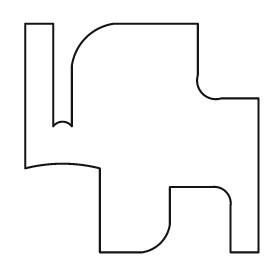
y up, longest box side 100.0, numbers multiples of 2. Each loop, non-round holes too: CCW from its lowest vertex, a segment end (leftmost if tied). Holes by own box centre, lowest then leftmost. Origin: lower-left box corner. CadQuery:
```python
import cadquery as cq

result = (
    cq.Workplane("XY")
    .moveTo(32.0, 0.0)
    .lineTo(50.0, 0.0)
    .threePointArc((58.0, 4.0), (62.0, 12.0))
    .lineTo(62.0, 28.0)
    .lineTo(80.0, 28.0)
    .threePointArc((86.0, 26.0), (88.0, 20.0))
    .lineTo(88.0, 0.0)
    .lineTo(100.0, 0.0)
    .lineTo(100.0, 66.0)
    .lineTo(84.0, 66.0)
    .threePointArc((76.0, 68.0), (74.0, 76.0))
    .lineTo(74.0, 98.0)
    .lineTo(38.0, 98.0)
    .threePointArc((26.0, 92.0), (20.0, 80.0))
    .lineTo(20.0, 54.0)
    .threePointArc((16.0, 56.0), (12.0, 54.0))
    .lineTo(12.0, 98.0)
    .lineTo(0.0, 98.0)
    .lineTo(0.0, 36.0)
    .threePointArc((16.0, 38.0), (32.0, 36.0))
    .close()
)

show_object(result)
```